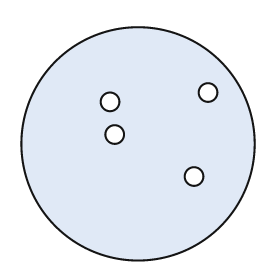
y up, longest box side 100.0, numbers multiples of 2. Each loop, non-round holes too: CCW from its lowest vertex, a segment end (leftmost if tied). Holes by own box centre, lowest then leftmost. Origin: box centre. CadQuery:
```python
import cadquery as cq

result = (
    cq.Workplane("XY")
    .moveTo(0.0, 0.0)
    .circle(50.0)
    .moveTo(24.0, -14.0)
    .circle(4.0)
    .moveTo(-10.0, 4.0)
    .circle(4.0)
    .moveTo(-12.0, 18.0)
    .circle(4.0)
    .moveTo(30.0, 22.0)
    .circle(4.0)
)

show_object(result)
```